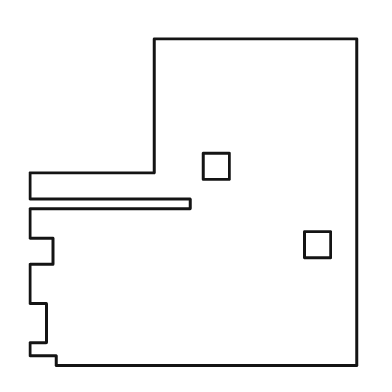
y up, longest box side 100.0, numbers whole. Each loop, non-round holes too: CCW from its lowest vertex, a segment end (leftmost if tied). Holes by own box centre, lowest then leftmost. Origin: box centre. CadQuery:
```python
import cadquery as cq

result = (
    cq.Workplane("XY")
    .moveTo(-42.0, -50.0)
    .lineTo(50.0, -50.0)
    .lineTo(50.0, 50.0)
    .lineTo(-12.0, 50.0)
    .lineTo(-12.0, 9.0)
    .lineTo(-50.0, 9.0)
    .lineTo(-50.0, 1.0)
    .lineTo(-1.0, 1.0)
    .lineTo(-1.0, -2.0)
    .lineTo(-50.0, -2.0)
    .lineTo(-50.0, -11.0)
    .lineTo(-43.0, -11.0)
    .lineTo(-43.0, -19.0)
    .lineTo(-50.0, -19.0)
    .lineTo(-50.0, -31.0)
    .lineTo(-45.0, -31.0)
    .lineTo(-45.0, -43.0)
    .lineTo(-50.0, -43.0)
    .lineTo(-50.0, -47.0)
    .lineTo(-42.0, -47.0)
    .close()
    .moveTo(34.0, -17.0)
    .lineTo(42.0, -17.0)
    .lineTo(42.0, -9.0)
    .lineTo(34.0, -9.0)
    .close()
    .moveTo(3.0, 7.0)
    .lineTo(11.0, 7.0)
    .lineTo(11.0, 15.0)
    .lineTo(3.0, 15.0)
    .close()
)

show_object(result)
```